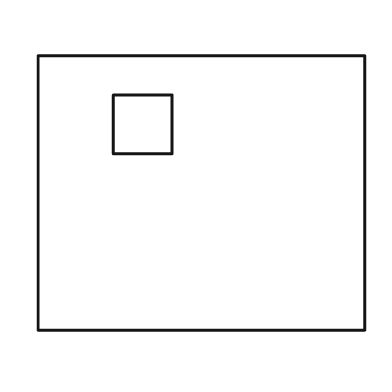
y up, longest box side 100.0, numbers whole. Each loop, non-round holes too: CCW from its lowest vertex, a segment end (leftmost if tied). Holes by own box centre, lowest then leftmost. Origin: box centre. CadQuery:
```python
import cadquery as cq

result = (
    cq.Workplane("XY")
    .moveTo(-50.0, -42.0)
    .lineTo(50.0, -42.0)
    .lineTo(50.0, 42.0)
    .lineTo(-50.0, 42.0)
    .close()
    .moveTo(-27.0, 12.0)
    .lineTo(-9.0, 12.0)
    .lineTo(-9.0, 30.0)
    .lineTo(-27.0, 30.0)
    .close()
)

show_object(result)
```